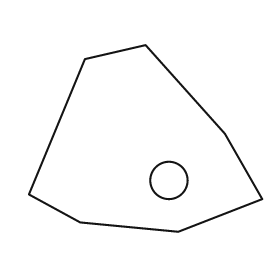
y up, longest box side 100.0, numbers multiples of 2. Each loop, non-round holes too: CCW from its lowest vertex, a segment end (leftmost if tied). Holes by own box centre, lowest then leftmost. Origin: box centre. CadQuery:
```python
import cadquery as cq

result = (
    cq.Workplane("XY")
    .moveTo(14.0, -40.0)
    .lineTo(50.0, -26.0)
    .lineTo(34.0, 2.0)
    .lineTo(0.0, 40.0)
    .lineTo(-26.0, 34.0)
    .lineTo(-50.0, -24.0)
    .lineTo(-28.0, -36.0)
    .close()
    .moveTo(10.0, -18.0)
    .circle(8.0)
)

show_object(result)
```